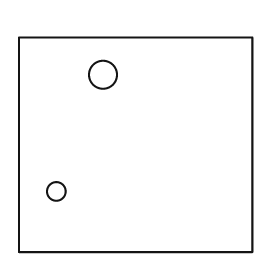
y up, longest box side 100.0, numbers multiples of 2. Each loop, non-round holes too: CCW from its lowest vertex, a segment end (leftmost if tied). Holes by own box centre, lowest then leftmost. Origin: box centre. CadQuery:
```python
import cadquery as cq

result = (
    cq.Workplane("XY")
    .moveTo(-50.0, -46.0)
    .lineTo(50.0, -46.0)
    .lineTo(50.0, 46.0)
    .lineTo(-50.0, 46.0)
    .close()
    .moveTo(-34.0, -20.0)
    .circle(4.0)
    .moveTo(-14.0, 30.0)
    .circle(6.0)
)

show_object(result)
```